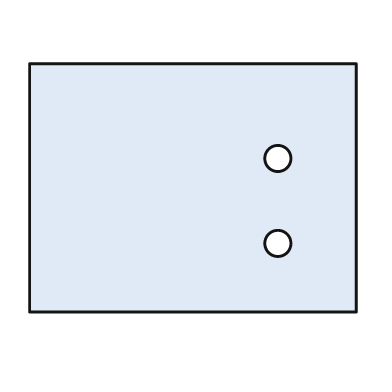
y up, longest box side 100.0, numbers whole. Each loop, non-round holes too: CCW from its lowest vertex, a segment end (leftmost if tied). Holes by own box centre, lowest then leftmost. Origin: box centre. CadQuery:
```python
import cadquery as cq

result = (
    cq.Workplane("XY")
    .moveTo(-50.0, -38.0)
    .lineTo(50.0, -38.0)
    .lineTo(50.0, 38.0)
    .lineTo(-50.0, 38.0)
    .close()
    .moveTo(26.0, -17.0)
    .circle(4.0)
    .moveTo(26.0, 9.0)
    .circle(4.0)
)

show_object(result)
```